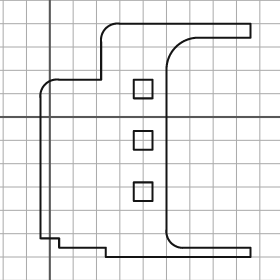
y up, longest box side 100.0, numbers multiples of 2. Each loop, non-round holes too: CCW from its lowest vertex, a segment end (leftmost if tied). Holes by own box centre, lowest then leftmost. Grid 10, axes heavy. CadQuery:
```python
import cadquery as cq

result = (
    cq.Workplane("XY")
    .moveTo(24.0, -60.0)
    .lineTo(86.0, -60.0)
    .lineTo(86.0, -56.0)
    .lineTo(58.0, -56.0)
    .threePointArc((52.0, -54.0), (50.0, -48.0))
    .lineTo(50.0, 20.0)
    .threePointArc((54.0, 30.0), (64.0, 34.0))
    .lineTo(86.0, 34.0)
    .lineTo(86.0, 40.0)
    .lineTo(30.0, 40.0)
    .threePointArc((24.0, 38.0), (22.0, 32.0))
    .lineTo(22.0, 16.0)
    .lineTo(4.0, 16.0)
    .threePointArc((-2.0, 14.0), (-4.0, 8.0))
    .lineTo(-4.0, -52.0)
    .lineTo(4.0, -52.0)
    .lineTo(4.0, -56.0)
    .lineTo(24.0, -56.0)
    .close()
    .moveTo(36.0, -36.0)
    .lineTo(44.0, -36.0)
    .lineTo(44.0, -28.0)
    .lineTo(36.0, -28.0)
    .close()
    .moveTo(36.0, -14.0)
    .lineTo(44.0, -14.0)
    .lineTo(44.0, -6.0)
    .lineTo(36.0, -6.0)
    .close()
    .moveTo(36.0, 8.0)
    .lineTo(44.0, 8.0)
    .lineTo(44.0, 16.0)
    .lineTo(36.0, 16.0)
    .close()
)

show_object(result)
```